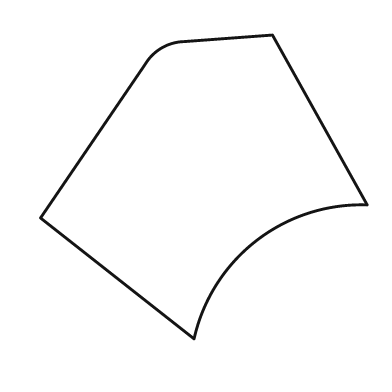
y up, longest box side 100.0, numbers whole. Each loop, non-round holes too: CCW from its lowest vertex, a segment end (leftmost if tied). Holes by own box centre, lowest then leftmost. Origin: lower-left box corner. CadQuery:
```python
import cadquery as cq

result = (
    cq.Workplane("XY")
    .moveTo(47.0, 0.0)
    .threePointArc((66.0, 30.0), (100.0, 41.0))
    .lineTo(71.0, 93.0)
    .lineTo(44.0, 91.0)
    .threePointArc((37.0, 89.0), (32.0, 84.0))
    .lineTo(0.0, 37.0)
    .close()
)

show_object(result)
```